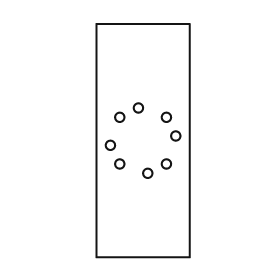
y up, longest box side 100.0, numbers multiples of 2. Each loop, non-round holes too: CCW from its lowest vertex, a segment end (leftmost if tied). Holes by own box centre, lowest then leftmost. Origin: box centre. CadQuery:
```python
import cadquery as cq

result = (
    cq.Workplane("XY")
    .moveTo(-20.0, -50.0)
    .lineTo(20.0, -50.0)
    .lineTo(20.0, 50.0)
    .lineTo(-20.0, 50.0)
    .close()
    .moveTo(2.0, -14.0)
    .circle(2.0)
    .moveTo(-10.0, -10.0)
    .circle(2.0)
    .moveTo(10.0, -10.0)
    .circle(2.0)
    .moveTo(-14.0, -2.0)
    .circle(2.0)
    .moveTo(14.0, 2.0)
    .circle(2.0)
    .moveTo(-10.0, 10.0)
    .circle(2.0)
    .moveTo(10.0, 10.0)
    .circle(2.0)
    .moveTo(-2.0, 14.0)
    .circle(2.0)
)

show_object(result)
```